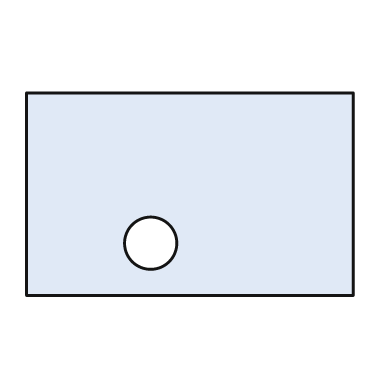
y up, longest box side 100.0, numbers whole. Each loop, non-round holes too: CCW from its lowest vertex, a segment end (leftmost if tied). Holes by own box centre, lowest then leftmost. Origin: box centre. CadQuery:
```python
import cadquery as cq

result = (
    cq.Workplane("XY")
    .moveTo(-50.0, -31.0)
    .lineTo(50.0, -31.0)
    .lineTo(50.0, 31.0)
    .lineTo(-50.0, 31.0)
    .close()
    .moveTo(-12.0, -15.0)
    .circle(8.0)
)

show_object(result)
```